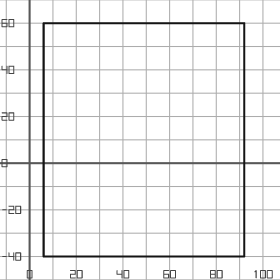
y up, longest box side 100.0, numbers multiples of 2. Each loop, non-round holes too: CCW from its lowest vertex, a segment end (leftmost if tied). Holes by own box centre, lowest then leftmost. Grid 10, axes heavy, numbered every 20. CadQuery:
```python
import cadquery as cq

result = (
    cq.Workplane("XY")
    .moveTo(6.0, -40.0)
    .lineTo(92.0, -40.0)
    .lineTo(92.0, 60.0)
    .lineTo(6.0, 60.0)
    .close()
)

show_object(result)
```